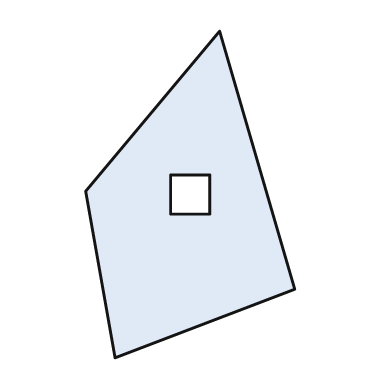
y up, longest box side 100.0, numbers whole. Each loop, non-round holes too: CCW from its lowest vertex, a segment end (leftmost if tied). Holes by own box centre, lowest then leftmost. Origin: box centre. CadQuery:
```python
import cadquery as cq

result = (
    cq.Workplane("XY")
    .moveTo(-23.0, -50.0)
    .lineTo(32.0, -29.0)
    .lineTo(9.0, 50.0)
    .lineTo(-32.0, 1.0)
    .close()
    .moveTo(-6.0, -6.0)
    .lineTo(6.0, -6.0)
    .lineTo(6.0, 6.0)
    .lineTo(-6.0, 6.0)
    .close()
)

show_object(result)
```